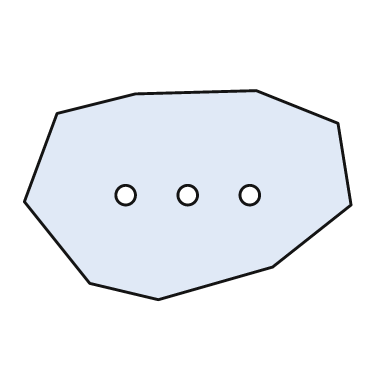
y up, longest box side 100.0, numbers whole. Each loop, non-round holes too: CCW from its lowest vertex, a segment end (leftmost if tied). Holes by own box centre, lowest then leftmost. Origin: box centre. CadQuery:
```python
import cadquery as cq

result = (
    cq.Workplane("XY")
    .moveTo(-9.0, -32.0)
    .lineTo(26.0, -22.0)
    .lineTo(50.0, -3.0)
    .lineTo(46.0, 22.0)
    .lineTo(21.0, 32.0)
    .lineTo(-16.0, 31.0)
    .lineTo(-40.0, 25.0)
    .lineTo(-50.0, -2.0)
    .lineTo(-30.0, -27.0)
    .close()
    .moveTo(-19.0, 0.0)
    .circle(3.0)
    .moveTo(0.0, 0.0)
    .circle(3.0)
    .moveTo(19.0, 0.0)
    .circle(3.0)
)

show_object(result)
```